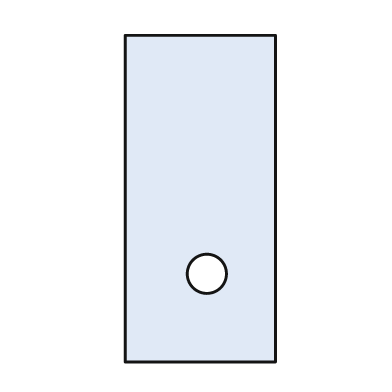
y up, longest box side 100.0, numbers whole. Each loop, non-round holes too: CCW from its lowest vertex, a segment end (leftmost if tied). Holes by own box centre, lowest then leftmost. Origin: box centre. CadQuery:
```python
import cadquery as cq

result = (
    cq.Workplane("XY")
    .moveTo(-23.0, -50.0)
    .lineTo(23.0, -50.0)
    .lineTo(23.0, 50.0)
    .lineTo(-23.0, 50.0)
    .close()
    .moveTo(2.0, -23.0)
    .circle(6.0)
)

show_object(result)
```